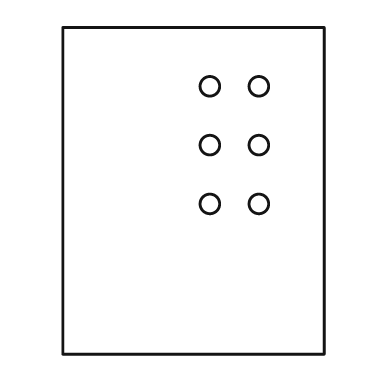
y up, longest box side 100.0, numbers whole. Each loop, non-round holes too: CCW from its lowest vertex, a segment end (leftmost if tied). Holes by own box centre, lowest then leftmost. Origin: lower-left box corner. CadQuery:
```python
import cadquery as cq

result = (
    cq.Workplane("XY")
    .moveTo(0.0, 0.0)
    .lineTo(80.0, 0.0)
    .lineTo(80.0, 100.0)
    .lineTo(0.0, 100.0)
    .close()
    .moveTo(45.0, 46.0)
    .circle(3.0)
    .moveTo(60.0, 46.0)
    .circle(3.0)
    .moveTo(45.0, 64.0)
    .circle(3.0)
    .moveTo(60.0, 64.0)
    .circle(3.0)
    .moveTo(45.0, 82.0)
    .circle(3.0)
    .moveTo(60.0, 82.0)
    .circle(3.0)
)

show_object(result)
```